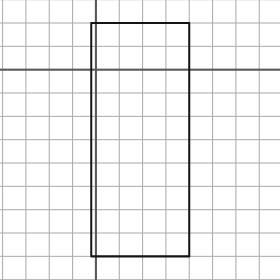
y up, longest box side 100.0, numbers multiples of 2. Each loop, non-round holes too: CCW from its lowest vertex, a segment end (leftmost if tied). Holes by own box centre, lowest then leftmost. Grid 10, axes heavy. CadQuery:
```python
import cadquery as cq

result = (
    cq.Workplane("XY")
    .moveTo(-2.0, -80.0)
    .lineTo(40.0, -80.0)
    .lineTo(40.0, 20.0)
    .lineTo(-2.0, 20.0)
    .close()
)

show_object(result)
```